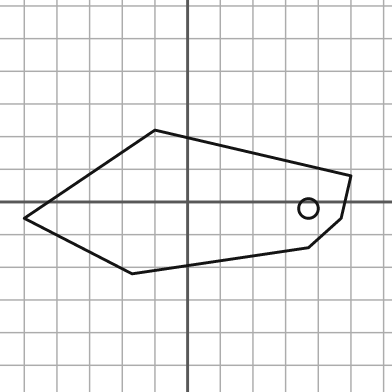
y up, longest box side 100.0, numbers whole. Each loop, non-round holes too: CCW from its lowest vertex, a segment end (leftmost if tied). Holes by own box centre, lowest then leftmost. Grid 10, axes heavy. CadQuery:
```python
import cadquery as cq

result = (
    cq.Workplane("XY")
    .moveTo(-17.0, -22.0)
    .lineTo(37.0, -14.0)
    .lineTo(47.0, -5.0)
    .lineTo(50.0, 8.0)
    .lineTo(-10.0, 22.0)
    .lineTo(-50.0, -5.0)
    .close()
    .moveTo(37.0, -2.0)
    .circle(3.0)
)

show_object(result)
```